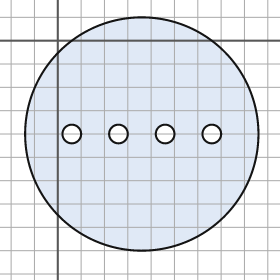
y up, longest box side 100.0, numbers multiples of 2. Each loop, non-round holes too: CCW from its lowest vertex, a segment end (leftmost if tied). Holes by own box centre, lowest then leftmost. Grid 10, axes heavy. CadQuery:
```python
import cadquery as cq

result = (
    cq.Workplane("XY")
    .moveTo(36.0, -40.0)
    .circle(50.0)
    .moveTo(6.0, -40.0)
    .circle(4.0)
    .moveTo(26.0, -40.0)
    .circle(4.0)
    .moveTo(46.0, -40.0)
    .circle(4.0)
    .moveTo(66.0, -40.0)
    .circle(4.0)
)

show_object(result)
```